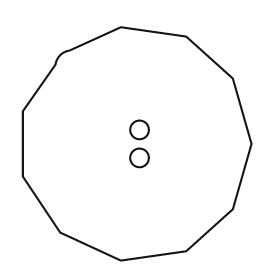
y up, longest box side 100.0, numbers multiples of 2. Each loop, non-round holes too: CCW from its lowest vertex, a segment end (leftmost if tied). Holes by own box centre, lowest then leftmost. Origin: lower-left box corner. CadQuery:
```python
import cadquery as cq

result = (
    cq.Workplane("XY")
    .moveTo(42.0, 0.0)
    .lineTo(70.0, 4.0)
    .lineTo(90.0, 22.0)
    .lineTo(98.0, 50.0)
    .lineTo(90.0, 78.0)
    .lineTo(70.0, 96.0)
    .lineTo(42.0, 100.0)
    .lineTo(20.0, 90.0)
    .threePointArc((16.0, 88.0), (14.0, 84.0))
    .lineTo(0.0, 64.0)
    .lineTo(0.0, 36.0)
    .lineTo(16.0, 12.0)
    .close()
    .moveTo(50.0, 44.0)
    .circle(4.0)
    .moveTo(50.0, 56.0)
    .circle(4.0)
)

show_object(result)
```